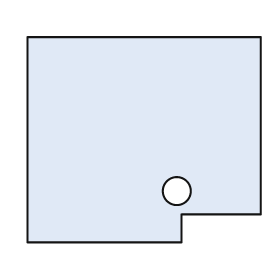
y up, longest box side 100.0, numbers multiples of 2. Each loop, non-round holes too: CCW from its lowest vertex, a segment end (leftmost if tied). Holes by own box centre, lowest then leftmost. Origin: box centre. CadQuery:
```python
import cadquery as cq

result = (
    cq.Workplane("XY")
    .moveTo(-50.0, -44.0)
    .lineTo(16.0, -44.0)
    .lineTo(16.0, -32.0)
    .lineTo(50.0, -32.0)
    .lineTo(50.0, 44.0)
    .lineTo(-50.0, 44.0)
    .close()
    .moveTo(14.0, -22.0)
    .circle(6.0)
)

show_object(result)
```